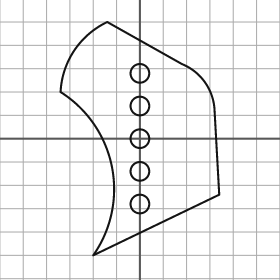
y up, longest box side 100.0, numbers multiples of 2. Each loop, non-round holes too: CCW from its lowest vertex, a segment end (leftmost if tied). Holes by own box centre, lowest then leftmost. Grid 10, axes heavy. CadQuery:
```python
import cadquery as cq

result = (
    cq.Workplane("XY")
    .moveTo(-20.0, -50.0)
    .lineTo(34.0, -24.0)
    .lineTo(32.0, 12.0)
    .threePointArc((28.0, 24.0), (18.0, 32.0))
    .lineTo(-14.0, 50.0)
    .threePointArc((-28.0, 38.0), (-34.0, 20.0))
    .threePointArc((-12.0, -12.0), (-20.0, -50.0))
    .close()
    .moveTo(0.0, -28.0)
    .circle(4.0)
    .moveTo(0.0, -14.0)
    .circle(4.0)
    .moveTo(0.0, 0.0)
    .circle(4.0)
    .moveTo(0.0, 14.0)
    .circle(4.0)
    .moveTo(0.0, 28.0)
    .circle(4.0)
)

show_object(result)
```